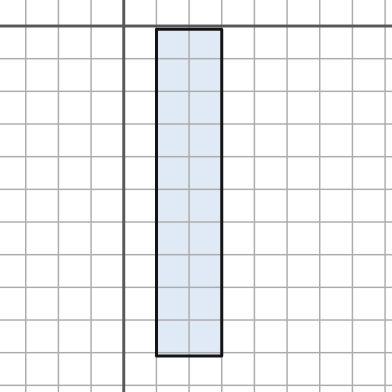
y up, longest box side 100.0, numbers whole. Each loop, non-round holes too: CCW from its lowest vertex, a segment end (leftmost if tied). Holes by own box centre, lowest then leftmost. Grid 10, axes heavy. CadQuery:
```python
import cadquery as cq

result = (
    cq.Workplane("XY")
    .moveTo(10.0, -101.0)
    .lineTo(30.0, -101.0)
    .lineTo(30.0, -1.0)
    .lineTo(10.0, -1.0)
    .close()
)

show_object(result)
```